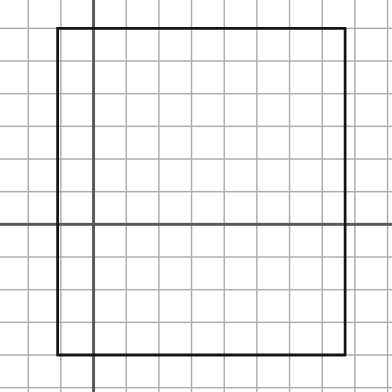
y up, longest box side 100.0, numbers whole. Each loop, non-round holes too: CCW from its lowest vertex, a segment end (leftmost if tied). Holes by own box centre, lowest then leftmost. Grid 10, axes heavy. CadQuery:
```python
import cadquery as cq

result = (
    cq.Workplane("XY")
    .moveTo(-11.0, -40.0)
    .lineTo(77.0, -40.0)
    .lineTo(77.0, 60.0)
    .lineTo(-11.0, 60.0)
    .close()
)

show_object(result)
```